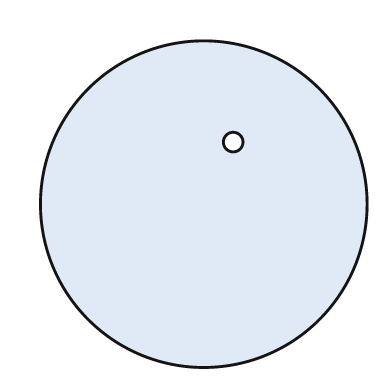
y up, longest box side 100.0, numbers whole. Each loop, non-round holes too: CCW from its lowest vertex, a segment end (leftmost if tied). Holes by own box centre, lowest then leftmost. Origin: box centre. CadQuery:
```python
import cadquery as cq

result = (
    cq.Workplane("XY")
    .moveTo(0.0, 0.0)
    .circle(50.0)
    .moveTo(9.0, 19.0)
    .circle(3.0)
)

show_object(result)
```